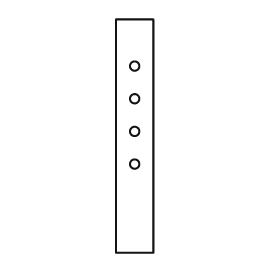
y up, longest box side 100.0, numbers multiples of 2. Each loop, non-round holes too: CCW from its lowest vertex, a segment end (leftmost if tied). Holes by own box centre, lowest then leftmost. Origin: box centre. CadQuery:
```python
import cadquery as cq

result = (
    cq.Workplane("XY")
    .moveTo(-8.0, -50.0)
    .lineTo(8.0, -50.0)
    .lineTo(8.0, 50.0)
    .lineTo(-8.0, 50.0)
    .close()
    .moveTo(0.0, -12.0)
    .circle(2.0)
    .moveTo(0.0, 2.0)
    .circle(2.0)
    .moveTo(0.0, 16.0)
    .circle(2.0)
    .moveTo(0.0, 30.0)
    .circle(2.0)
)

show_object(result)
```